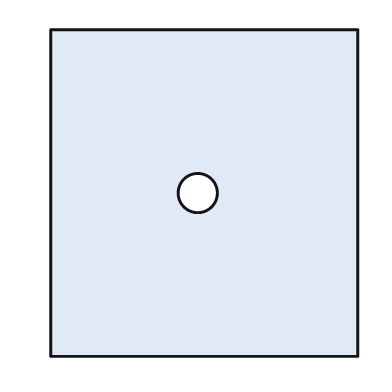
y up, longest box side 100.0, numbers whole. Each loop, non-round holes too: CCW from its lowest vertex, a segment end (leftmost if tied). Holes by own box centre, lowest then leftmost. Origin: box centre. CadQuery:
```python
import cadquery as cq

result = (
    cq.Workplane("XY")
    .moveTo(-47.0, -50.0)
    .lineTo(47.0, -50.0)
    .lineTo(47.0, 50.0)
    .lineTo(-47.0, 50.0)
    .close()
    .moveTo(-2.0, 0.0)
    .circle(6.0)
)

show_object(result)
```